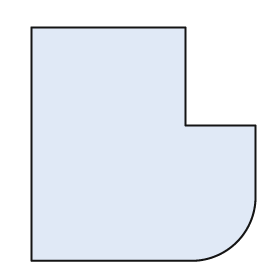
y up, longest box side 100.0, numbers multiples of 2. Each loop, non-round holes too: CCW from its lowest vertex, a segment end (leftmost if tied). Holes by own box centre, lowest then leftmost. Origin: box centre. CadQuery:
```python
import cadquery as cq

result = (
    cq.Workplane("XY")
    .moveTo(-48.0, -50.0)
    .lineTo(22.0, -50.0)
    .threePointArc((40.0, -42.0), (48.0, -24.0))
    .lineTo(48.0, 8.0)
    .lineTo(18.0, 8.0)
    .lineTo(18.0, 50.0)
    .lineTo(-48.0, 50.0)
    .close()
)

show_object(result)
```